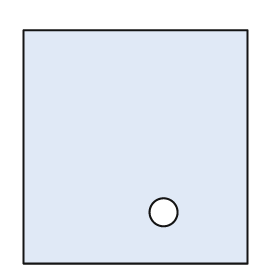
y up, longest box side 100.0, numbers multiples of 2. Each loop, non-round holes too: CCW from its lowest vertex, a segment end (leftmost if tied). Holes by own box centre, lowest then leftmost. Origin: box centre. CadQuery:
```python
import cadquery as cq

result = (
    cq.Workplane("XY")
    .moveTo(-48.0, -50.0)
    .lineTo(48.0, -50.0)
    .lineTo(48.0, 50.0)
    .lineTo(-48.0, 50.0)
    .close()
    .moveTo(12.0, -28.0)
    .circle(6.0)
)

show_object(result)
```